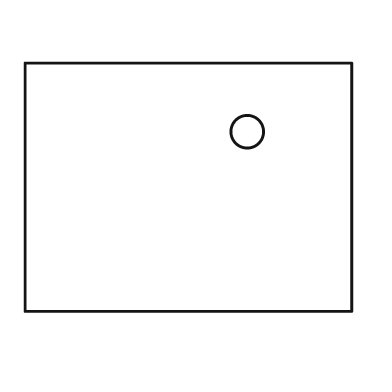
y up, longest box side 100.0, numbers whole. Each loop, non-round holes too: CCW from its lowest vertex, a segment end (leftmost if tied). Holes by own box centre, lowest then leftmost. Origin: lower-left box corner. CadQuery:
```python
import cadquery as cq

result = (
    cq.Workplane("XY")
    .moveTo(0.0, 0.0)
    .lineTo(100.0, 0.0)
    .lineTo(100.0, 76.0)
    .lineTo(0.0, 76.0)
    .close()
    .moveTo(68.0, 55.0)
    .circle(5.0)
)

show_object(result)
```